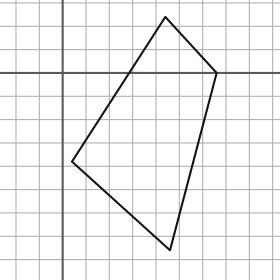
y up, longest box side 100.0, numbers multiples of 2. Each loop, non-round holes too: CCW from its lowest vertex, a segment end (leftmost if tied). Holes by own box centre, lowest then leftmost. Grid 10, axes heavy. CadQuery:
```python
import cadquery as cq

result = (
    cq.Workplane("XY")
    .moveTo(46.0, -76.0)
    .lineTo(66.0, 0.0)
    .lineTo(44.0, 24.0)
    .lineTo(4.0, -38.0)
    .close()
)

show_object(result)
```